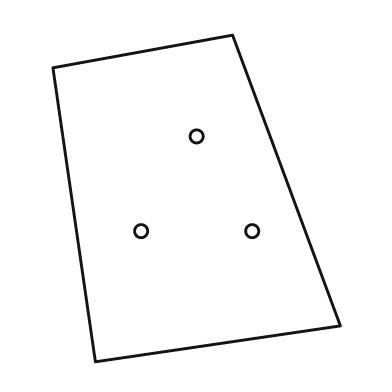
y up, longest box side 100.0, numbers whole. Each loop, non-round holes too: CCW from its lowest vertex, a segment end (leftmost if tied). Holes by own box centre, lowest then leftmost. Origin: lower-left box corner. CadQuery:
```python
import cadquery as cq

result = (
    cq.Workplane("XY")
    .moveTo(13.0, 0.0)
    .lineTo(88.0, 11.0)
    .lineTo(55.0, 100.0)
    .lineTo(0.0, 90.0)
    .close()
    .moveTo(27.0, 40.0)
    .circle(2.0)
    .moveTo(61.0, 40.0)
    .circle(2.0)
    .moveTo(44.0, 69.0)
    .circle(2.0)
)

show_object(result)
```